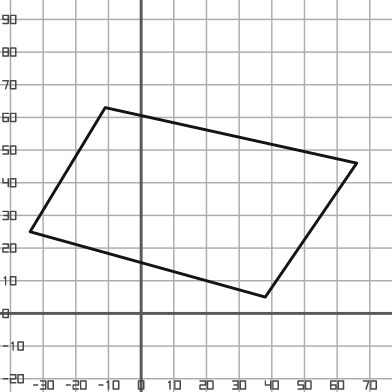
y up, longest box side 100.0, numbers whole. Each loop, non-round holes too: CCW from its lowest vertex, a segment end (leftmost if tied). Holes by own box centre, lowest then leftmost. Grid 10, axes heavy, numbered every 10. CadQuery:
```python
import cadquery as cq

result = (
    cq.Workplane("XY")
    .moveTo(38.0, 5.0)
    .lineTo(66.0, 46.0)
    .lineTo(-11.0, 63.0)
    .lineTo(-34.0, 25.0)
    .close()
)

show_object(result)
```